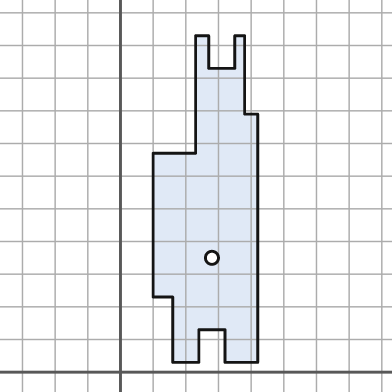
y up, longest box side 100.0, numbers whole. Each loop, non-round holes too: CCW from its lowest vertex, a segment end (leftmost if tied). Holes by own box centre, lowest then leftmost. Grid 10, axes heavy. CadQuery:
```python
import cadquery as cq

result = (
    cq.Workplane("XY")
    .moveTo(16.0, 3.0)
    .lineTo(24.0, 3.0)
    .lineTo(24.0, 13.0)
    .lineTo(32.0, 13.0)
    .lineTo(32.0, 3.0)
    .lineTo(42.0, 3.0)
    .lineTo(42.0, 79.0)
    .lineTo(38.0, 79.0)
    .lineTo(38.0, 103.0)
    .lineTo(35.0, 103.0)
    .lineTo(35.0, 93.0)
    .lineTo(27.0, 93.0)
    .lineTo(27.0, 103.0)
    .lineTo(23.0, 103.0)
    .lineTo(23.0, 67.0)
    .lineTo(10.0, 67.0)
    .lineTo(10.0, 23.0)
    .lineTo(16.0, 23.0)
    .close()
    .moveTo(28.0, 35.0)
    .circle(2.0)
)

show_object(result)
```